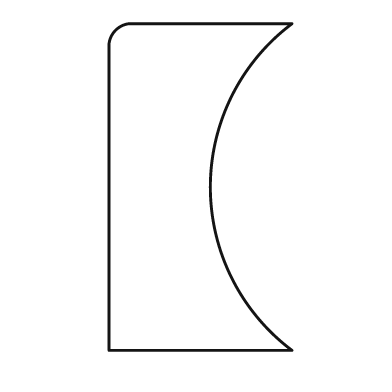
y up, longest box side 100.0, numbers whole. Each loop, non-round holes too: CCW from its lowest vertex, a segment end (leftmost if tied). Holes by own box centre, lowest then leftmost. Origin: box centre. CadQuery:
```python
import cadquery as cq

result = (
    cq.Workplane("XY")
    .moveTo(-28.0, -50.0)
    .lineTo(28.0, -50.0)
    .threePointArc((3.0, 0.0), (28.0, 50.0))
    .lineTo(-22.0, 50.0)
    .threePointArc((-26.0, 48.0), (-28.0, 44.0))
    .close()
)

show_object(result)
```